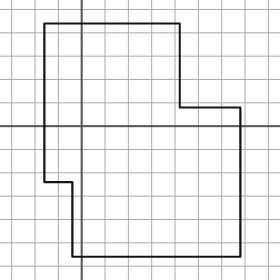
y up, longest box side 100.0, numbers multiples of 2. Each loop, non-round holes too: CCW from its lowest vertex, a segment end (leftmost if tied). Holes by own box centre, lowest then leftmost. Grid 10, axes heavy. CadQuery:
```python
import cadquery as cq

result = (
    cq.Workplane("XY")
    .moveTo(-4.0, -56.0)
    .lineTo(68.0, -56.0)
    .lineTo(68.0, 8.0)
    .lineTo(42.0, 8.0)
    .lineTo(42.0, 44.0)
    .lineTo(-16.0, 44.0)
    .lineTo(-16.0, -24.0)
    .lineTo(-4.0, -24.0)
    .close()
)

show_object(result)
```